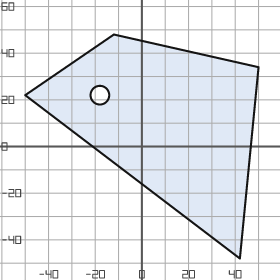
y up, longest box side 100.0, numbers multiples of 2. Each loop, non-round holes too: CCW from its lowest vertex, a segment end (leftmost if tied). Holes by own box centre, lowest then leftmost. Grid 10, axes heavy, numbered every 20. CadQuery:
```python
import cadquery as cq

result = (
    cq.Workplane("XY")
    .moveTo(42.0, -48.0)
    .lineTo(50.0, 34.0)
    .lineTo(-12.0, 48.0)
    .lineTo(-50.0, 22.0)
    .close()
    .moveTo(-18.0, 22.0)
    .circle(4.0)
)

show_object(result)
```